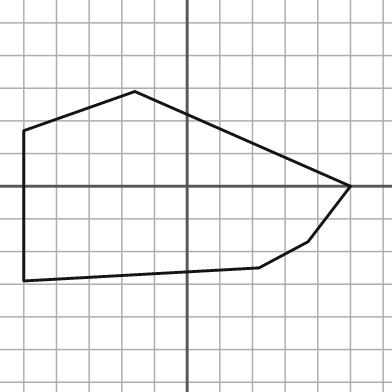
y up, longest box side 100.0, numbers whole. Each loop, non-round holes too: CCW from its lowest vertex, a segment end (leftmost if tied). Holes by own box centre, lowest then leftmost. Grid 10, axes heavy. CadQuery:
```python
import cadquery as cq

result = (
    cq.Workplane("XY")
    .moveTo(-50.0, -29.0)
    .lineTo(22.0, -25.0)
    .lineTo(37.0, -17.0)
    .lineTo(50.0, 0.0)
    .lineTo(-16.0, 29.0)
    .lineTo(-50.0, 17.0)
    .close()
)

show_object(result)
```